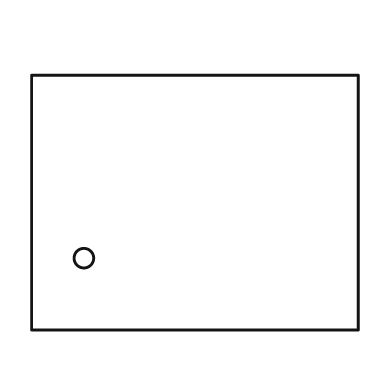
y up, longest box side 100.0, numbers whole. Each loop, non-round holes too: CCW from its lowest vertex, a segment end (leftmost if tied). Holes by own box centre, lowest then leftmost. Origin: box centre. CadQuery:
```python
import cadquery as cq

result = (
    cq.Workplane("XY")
    .moveTo(-50.0, -39.0)
    .lineTo(50.0, -39.0)
    .lineTo(50.0, 39.0)
    .lineTo(-50.0, 39.0)
    .close()
    .moveTo(-34.0, -17.0)
    .circle(3.0)
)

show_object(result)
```